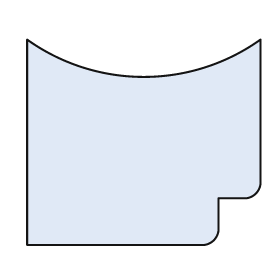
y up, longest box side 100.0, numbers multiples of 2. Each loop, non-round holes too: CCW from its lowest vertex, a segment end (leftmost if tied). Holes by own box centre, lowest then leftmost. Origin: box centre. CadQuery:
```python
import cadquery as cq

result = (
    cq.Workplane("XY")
    .moveTo(-50.0, -44.0)
    .lineTo(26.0, -44.0)
    .threePointArc((30.0, -42.0), (32.0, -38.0))
    .lineTo(32.0, -24.0)
    .lineTo(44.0, -24.0)
    .threePointArc((48.0, -22.0), (50.0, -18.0))
    .lineTo(50.0, 44.0)
    .threePointArc((0.0, 28.0), (-50.0, 44.0))
    .close()
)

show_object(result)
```